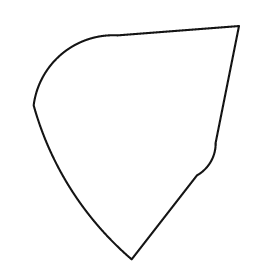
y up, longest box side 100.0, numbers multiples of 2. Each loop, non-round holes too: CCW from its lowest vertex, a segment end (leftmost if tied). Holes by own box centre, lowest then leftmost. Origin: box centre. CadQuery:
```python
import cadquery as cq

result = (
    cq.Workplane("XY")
    .moveTo(-2.0, -50.0)
    .lineTo(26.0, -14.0)
    .threePointArc((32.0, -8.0), (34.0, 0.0))
    .lineTo(44.0, 50.0)
    .lineTo(-8.0, 46.0)
    .threePointArc((-32.0, 38.0), (-44.0, 16.0))
    .threePointArc((-28.0, -20.0), (-2.0, -50.0))
    .close()
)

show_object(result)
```